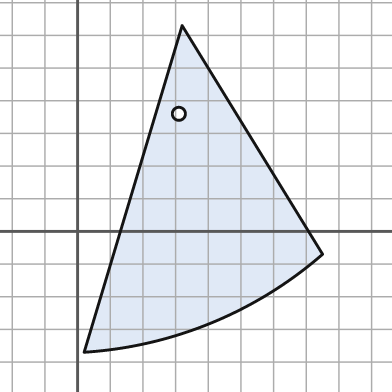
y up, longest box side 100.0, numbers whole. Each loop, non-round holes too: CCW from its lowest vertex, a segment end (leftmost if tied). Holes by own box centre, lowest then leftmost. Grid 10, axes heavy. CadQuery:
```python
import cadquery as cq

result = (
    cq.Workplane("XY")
    .moveTo(2.0, -37.0)
    .threePointArc((41.0, -28.0), (75.0, -7.0))
    .lineTo(32.0, 63.0)
    .close()
    .moveTo(31.0, 36.0)
    .circle(2.0)
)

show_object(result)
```